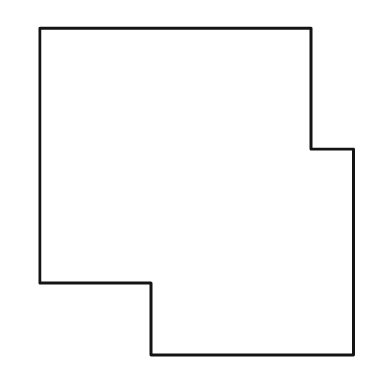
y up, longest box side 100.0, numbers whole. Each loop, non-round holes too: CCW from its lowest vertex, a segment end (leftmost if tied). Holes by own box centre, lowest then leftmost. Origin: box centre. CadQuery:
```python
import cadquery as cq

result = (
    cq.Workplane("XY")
    .moveTo(-14.0, -50.0)
    .lineTo(48.0, -50.0)
    .lineTo(48.0, 13.0)
    .lineTo(35.0, 13.0)
    .lineTo(35.0, 50.0)
    .lineTo(-48.0, 50.0)
    .lineTo(-48.0, -28.0)
    .lineTo(-14.0, -28.0)
    .close()
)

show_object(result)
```